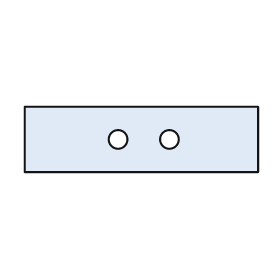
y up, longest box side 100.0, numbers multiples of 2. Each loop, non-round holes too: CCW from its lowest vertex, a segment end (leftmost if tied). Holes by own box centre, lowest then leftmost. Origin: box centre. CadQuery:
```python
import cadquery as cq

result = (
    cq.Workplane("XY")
    .moveTo(-50.0, -14.0)
    .lineTo(50.0, -14.0)
    .lineTo(50.0, 14.0)
    .lineTo(-50.0, 14.0)
    .close()
    .moveTo(-10.0, 0.0)
    .circle(4.0)
    .moveTo(12.0, 0.0)
    .circle(4.0)
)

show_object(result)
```